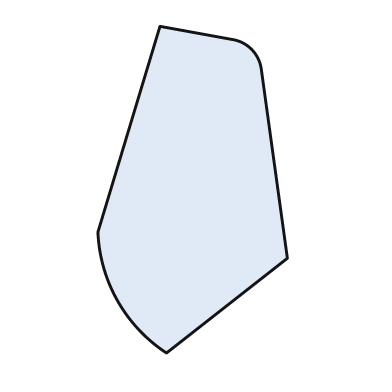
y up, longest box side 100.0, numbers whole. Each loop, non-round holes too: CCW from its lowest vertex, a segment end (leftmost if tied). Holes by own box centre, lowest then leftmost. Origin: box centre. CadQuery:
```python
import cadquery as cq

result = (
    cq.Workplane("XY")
    .moveTo(-8.0, -50.0)
    .lineTo(29.0, -21.0)
    .lineTo(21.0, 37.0)
    .threePointArc((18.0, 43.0), (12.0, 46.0))
    .lineTo(-10.0, 50.0)
    .lineTo(-29.0, -13.0)
    .threePointArc((-23.0, -34.0), (-8.0, -50.0))
    .close()
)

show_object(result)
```